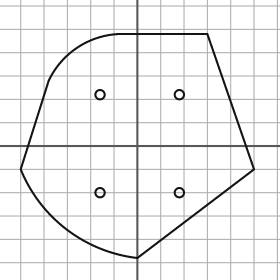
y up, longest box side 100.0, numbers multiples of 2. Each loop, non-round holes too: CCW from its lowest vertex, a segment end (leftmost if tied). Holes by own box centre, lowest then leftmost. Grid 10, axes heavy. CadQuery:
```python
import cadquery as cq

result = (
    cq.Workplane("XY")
    .moveTo(0.0, -48.0)
    .lineTo(50.0, -10.0)
    .lineTo(30.0, 48.0)
    .lineTo(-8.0, 48.0)
    .threePointArc((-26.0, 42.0), (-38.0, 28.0))
    .lineTo(-50.0, -10.0)
    .threePointArc((-30.0, -36.0), (0.0, -48.0))
    .close()
    .moveTo(-16.0, -20.0)
    .circle(2.0)
    .moveTo(18.0, -20.0)
    .circle(2.0)
    .moveTo(-16.0, 22.0)
    .circle(2.0)
    .moveTo(18.0, 22.0)
    .circle(2.0)
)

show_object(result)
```